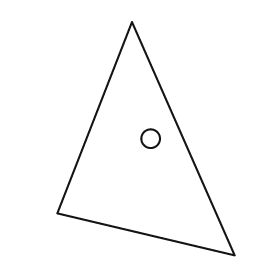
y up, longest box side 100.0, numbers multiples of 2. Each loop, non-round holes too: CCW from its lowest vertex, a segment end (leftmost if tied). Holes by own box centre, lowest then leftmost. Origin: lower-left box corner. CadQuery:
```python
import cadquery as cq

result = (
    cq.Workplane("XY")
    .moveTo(76.0, 0.0)
    .lineTo(32.0, 100.0)
    .lineTo(0.0, 18.0)
    .close()
    .moveTo(40.0, 50.0)
    .circle(4.0)
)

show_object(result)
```